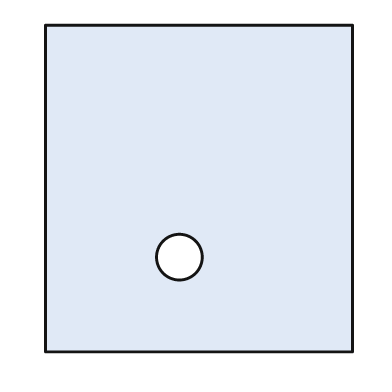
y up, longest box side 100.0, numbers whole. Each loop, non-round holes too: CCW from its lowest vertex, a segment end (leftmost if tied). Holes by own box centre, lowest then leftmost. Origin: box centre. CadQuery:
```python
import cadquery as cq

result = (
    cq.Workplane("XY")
    .moveTo(-47.0, -50.0)
    .lineTo(47.0, -50.0)
    .lineTo(47.0, 50.0)
    .lineTo(-47.0, 50.0)
    .close()
    .moveTo(-6.0, -21.0)
    .circle(7.0)
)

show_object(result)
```